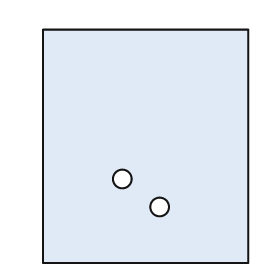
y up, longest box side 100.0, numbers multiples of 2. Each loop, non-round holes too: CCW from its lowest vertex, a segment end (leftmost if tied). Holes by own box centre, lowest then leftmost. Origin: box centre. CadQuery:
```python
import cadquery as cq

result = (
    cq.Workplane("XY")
    .moveTo(-44.0, -50.0)
    .lineTo(44.0, -50.0)
    .lineTo(44.0, 50.0)
    .lineTo(-44.0, 50.0)
    .close()
    .moveTo(6.0, -26.0)
    .circle(4.0)
    .moveTo(-10.0, -14.0)
    .circle(4.0)
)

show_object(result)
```